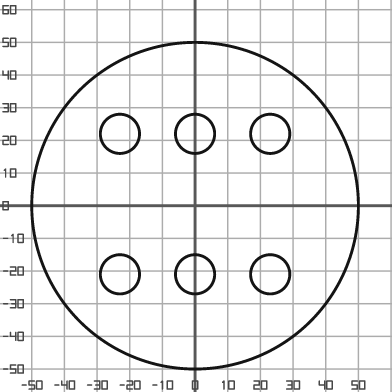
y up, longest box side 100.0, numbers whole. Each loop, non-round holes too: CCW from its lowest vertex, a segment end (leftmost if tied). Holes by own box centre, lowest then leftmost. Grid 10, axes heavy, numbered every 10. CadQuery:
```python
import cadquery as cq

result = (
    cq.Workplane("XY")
    .moveTo(0.0, 0.0)
    .circle(50.0)
    .moveTo(-23.0, -21.0)
    .circle(6.0)
    .moveTo(0.0, -21.0)
    .circle(6.0)
    .moveTo(23.0, -21.0)
    .circle(6.0)
    .moveTo(-23.0, 22.0)
    .circle(6.0)
    .moveTo(0.0, 22.0)
    .circle(6.0)
    .moveTo(23.0, 22.0)
    .circle(6.0)
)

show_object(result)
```